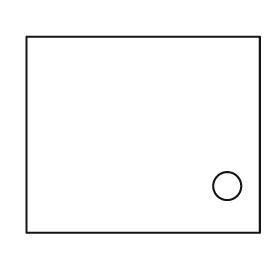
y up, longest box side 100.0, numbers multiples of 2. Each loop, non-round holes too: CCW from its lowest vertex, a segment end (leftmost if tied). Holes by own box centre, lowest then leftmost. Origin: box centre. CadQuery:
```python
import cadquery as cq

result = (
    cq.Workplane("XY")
    .moveTo(-50.0, -42.0)
    .lineTo(50.0, -42.0)
    .lineTo(50.0, 42.0)
    .lineTo(-50.0, 42.0)
    .close()
    .moveTo(36.0, -22.0)
    .circle(6.0)
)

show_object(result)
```